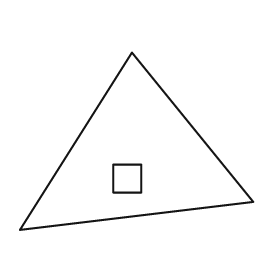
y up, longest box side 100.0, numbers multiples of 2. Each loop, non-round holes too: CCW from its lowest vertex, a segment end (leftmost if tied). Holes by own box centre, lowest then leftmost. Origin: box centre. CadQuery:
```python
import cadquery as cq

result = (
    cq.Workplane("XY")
    .moveTo(-50.0, -38.0)
    .lineTo(50.0, -26.0)
    .lineTo(-2.0, 38.0)
    .close()
    .moveTo(-10.0, -22.0)
    .lineTo(2.0, -22.0)
    .lineTo(2.0, -10.0)
    .lineTo(-10.0, -10.0)
    .close()
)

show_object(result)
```